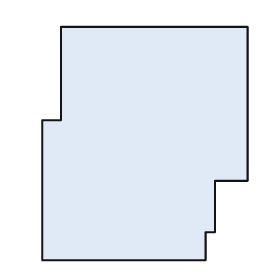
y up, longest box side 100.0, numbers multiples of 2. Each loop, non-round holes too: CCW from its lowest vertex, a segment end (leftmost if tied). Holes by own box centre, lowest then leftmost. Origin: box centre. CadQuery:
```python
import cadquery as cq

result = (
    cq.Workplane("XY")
    .moveTo(-44.0, -50.0)
    .lineTo(26.0, -50.0)
    .lineTo(26.0, -38.0)
    .lineTo(30.0, -38.0)
    .lineTo(30.0, -16.0)
    .lineTo(44.0, -16.0)
    .lineTo(44.0, 50.0)
    .lineTo(-36.0, 50.0)
    .lineTo(-36.0, 10.0)
    .lineTo(-44.0, 10.0)
    .close()
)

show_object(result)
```